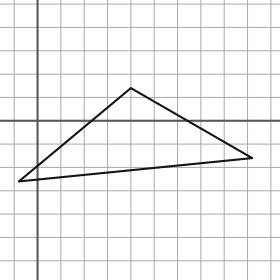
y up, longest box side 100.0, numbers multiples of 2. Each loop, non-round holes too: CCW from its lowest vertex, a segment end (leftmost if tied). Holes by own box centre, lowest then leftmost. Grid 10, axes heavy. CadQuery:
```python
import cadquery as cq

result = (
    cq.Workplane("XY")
    .moveTo(-8.0, -26.0)
    .lineTo(92.0, -16.0)
    .lineTo(40.0, 14.0)
    .close()
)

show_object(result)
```